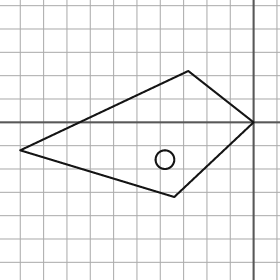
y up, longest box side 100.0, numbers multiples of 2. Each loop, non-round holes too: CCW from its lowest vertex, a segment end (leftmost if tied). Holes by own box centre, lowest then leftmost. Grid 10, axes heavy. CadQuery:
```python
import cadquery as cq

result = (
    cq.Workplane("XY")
    .moveTo(-34.0, -32.0)
    .lineTo(0.0, 0.0)
    .lineTo(-28.0, 22.0)
    .lineTo(-100.0, -12.0)
    .close()
    .moveTo(-38.0, -16.0)
    .circle(4.0)
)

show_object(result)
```